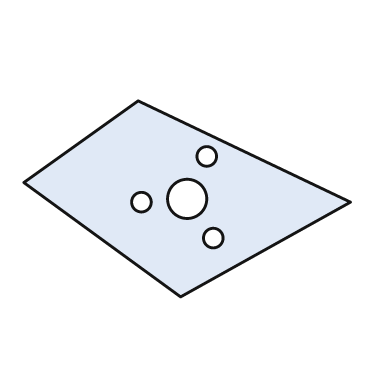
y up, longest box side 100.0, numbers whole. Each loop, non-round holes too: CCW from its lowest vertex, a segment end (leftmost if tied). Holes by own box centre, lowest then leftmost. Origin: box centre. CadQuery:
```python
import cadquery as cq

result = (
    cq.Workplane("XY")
    .moveTo(-2.0, -30.0)
    .lineTo(50.0, -1.0)
    .lineTo(-15.0, 30.0)
    .lineTo(-50.0, 5.0)
    .close()
    .moveTo(8.0, -12.0)
    .circle(3.0)
    .moveTo(-14.0, -1.0)
    .circle(3.0)
    .moveTo(0.0, 0.0)
    .circle(6.0)
    .moveTo(6.0, 13.0)
    .circle(3.0)
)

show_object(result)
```